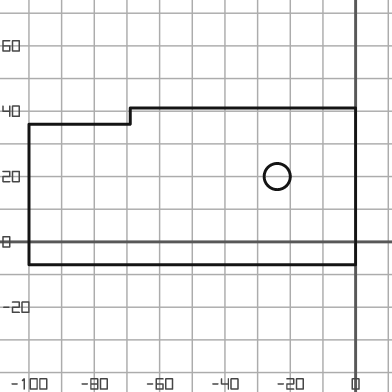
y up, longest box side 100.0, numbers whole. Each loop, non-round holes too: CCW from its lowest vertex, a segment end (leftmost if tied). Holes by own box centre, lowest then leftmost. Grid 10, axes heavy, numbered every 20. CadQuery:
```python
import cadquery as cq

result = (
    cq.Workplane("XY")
    .moveTo(-100.0, -7.0)
    .lineTo(0.0, -7.0)
    .lineTo(0.0, 41.0)
    .lineTo(-69.0, 41.0)
    .lineTo(-69.0, 36.0)
    .lineTo(-100.0, 36.0)
    .close()
    .moveTo(-24.0, 20.0)
    .circle(4.0)
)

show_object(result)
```